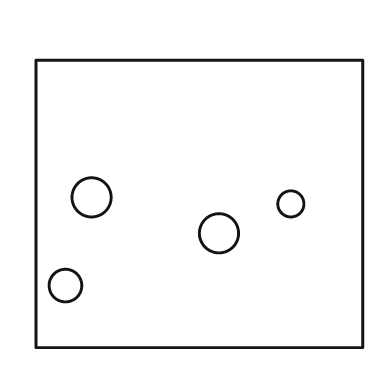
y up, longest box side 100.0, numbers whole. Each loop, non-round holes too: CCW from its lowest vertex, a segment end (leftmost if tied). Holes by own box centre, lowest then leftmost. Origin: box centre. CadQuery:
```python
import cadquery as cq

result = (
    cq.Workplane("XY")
    .moveTo(-50.0, -44.0)
    .lineTo(50.0, -44.0)
    .lineTo(50.0, 44.0)
    .lineTo(-50.0, 44.0)
    .close()
    .moveTo(-41.0, -25.0)
    .circle(5.0)
    .moveTo(6.0, -9.0)
    .circle(6.0)
    .moveTo(28.0, 0.0)
    .circle(4.0)
    .moveTo(-33.0, 2.0)
    .circle(6.0)
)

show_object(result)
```